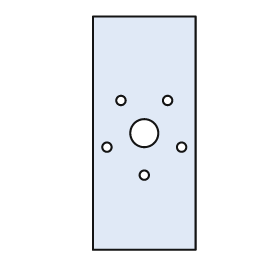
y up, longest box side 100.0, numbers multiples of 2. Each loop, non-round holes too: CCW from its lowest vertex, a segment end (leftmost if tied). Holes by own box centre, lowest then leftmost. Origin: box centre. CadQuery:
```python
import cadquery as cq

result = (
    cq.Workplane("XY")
    .moveTo(-22.0, -50.0)
    .lineTo(22.0, -50.0)
    .lineTo(22.0, 50.0)
    .lineTo(-22.0, 50.0)
    .close()
    .moveTo(0.0, -18.0)
    .circle(2.0)
    .moveTo(-16.0, -6.0)
    .circle(2.0)
    .moveTo(16.0, -6.0)
    .circle(2.0)
    .moveTo(0.0, 0.0)
    .circle(6.0)
    .moveTo(-10.0, 14.0)
    .circle(2.0)
    .moveTo(10.0, 14.0)
    .circle(2.0)
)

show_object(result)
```